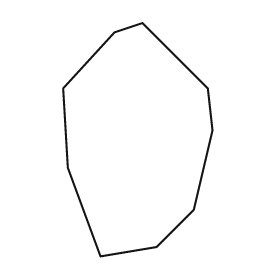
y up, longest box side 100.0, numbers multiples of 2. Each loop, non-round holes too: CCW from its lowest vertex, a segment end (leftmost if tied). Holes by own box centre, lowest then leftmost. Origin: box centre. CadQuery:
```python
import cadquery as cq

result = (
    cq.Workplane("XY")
    .moveTo(-16.0, -50.0)
    .lineTo(8.0, -46.0)
    .lineTo(24.0, -30.0)
    .lineTo(32.0, 4.0)
    .lineTo(30.0, 22.0)
    .lineTo(2.0, 50.0)
    .lineTo(-10.0, 46.0)
    .lineTo(-32.0, 22.0)
    .lineTo(-30.0, -12.0)
    .close()
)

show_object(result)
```